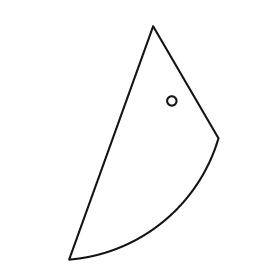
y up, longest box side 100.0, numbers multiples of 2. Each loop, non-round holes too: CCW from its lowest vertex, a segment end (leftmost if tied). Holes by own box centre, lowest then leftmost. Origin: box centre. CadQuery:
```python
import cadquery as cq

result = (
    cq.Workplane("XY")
    .moveTo(-32.0, -50.0)
    .threePointArc((8.0, -34.0), (32.0, 2.0))
    .lineTo(4.0, 50.0)
    .close()
    .moveTo(12.0, 18.0)
    .circle(2.0)
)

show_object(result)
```